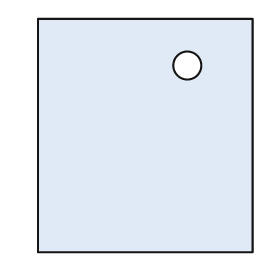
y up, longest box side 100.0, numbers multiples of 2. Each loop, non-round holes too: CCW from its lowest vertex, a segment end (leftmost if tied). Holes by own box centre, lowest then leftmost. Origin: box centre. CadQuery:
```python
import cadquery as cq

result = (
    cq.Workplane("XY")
    .moveTo(-46.0, -50.0)
    .lineTo(46.0, -50.0)
    .lineTo(46.0, 50.0)
    .lineTo(-46.0, 50.0)
    .close()
    .moveTo(18.0, 30.0)
    .circle(6.0)
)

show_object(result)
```